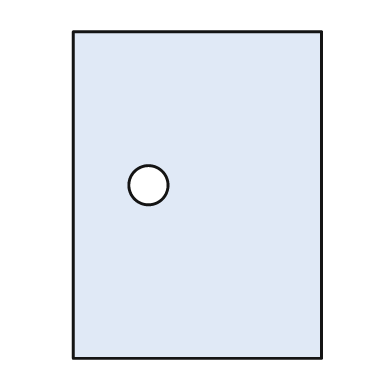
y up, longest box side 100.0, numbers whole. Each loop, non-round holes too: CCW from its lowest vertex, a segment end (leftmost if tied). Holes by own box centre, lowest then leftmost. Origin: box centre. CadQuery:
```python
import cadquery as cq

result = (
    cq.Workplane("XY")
    .moveTo(-38.0, -50.0)
    .lineTo(38.0, -50.0)
    .lineTo(38.0, 50.0)
    .lineTo(-38.0, 50.0)
    .close()
    .moveTo(-15.0, 3.0)
    .circle(6.0)
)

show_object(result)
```